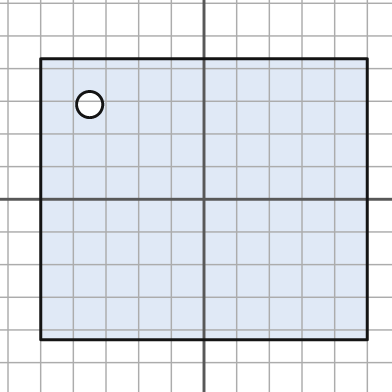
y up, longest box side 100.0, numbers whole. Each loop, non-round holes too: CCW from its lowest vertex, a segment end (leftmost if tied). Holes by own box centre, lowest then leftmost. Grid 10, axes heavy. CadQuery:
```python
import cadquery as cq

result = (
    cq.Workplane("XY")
    .moveTo(-50.0, -43.0)
    .lineTo(50.0, -43.0)
    .lineTo(50.0, 43.0)
    .lineTo(-50.0, 43.0)
    .close()
    .moveTo(-35.0, 29.0)
    .circle(4.0)
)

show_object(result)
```